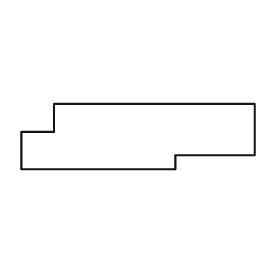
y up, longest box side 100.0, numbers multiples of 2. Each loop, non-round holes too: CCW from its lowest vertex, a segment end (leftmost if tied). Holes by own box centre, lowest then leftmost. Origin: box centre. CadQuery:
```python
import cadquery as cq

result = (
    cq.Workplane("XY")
    .moveTo(-50.0, -14.0)
    .lineTo(16.0, -14.0)
    .lineTo(16.0, -8.0)
    .lineTo(50.0, -8.0)
    .lineTo(50.0, 14.0)
    .lineTo(-36.0, 14.0)
    .lineTo(-36.0, 2.0)
    .lineTo(-50.0, 2.0)
    .close()
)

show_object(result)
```